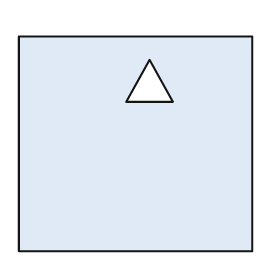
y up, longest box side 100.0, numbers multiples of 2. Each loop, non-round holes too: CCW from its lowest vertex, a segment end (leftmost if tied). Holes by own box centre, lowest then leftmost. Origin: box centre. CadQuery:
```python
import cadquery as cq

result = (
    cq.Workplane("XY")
    .moveTo(-50.0, -46.0)
    .lineTo(50.0, -46.0)
    .lineTo(50.0, 46.0)
    .lineTo(-50.0, 46.0)
    .close()
    .moveTo(-4.0, 18.0)
    .lineTo(16.0, 18.0)
    .lineTo(6.0, 36.0)
    .close()
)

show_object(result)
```